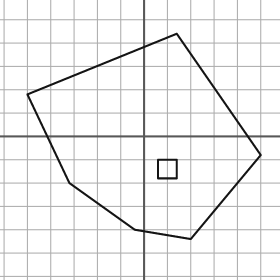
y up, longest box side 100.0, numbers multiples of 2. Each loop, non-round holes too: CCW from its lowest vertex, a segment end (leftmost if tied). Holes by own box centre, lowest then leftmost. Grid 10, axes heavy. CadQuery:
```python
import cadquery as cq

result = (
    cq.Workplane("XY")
    .moveTo(20.0, -44.0)
    .lineTo(50.0, -8.0)
    .lineTo(14.0, 44.0)
    .lineTo(-50.0, 18.0)
    .lineTo(-32.0, -20.0)
    .lineTo(-4.0, -40.0)
    .close()
    .moveTo(6.0, -18.0)
    .lineTo(14.0, -18.0)
    .lineTo(14.0, -10.0)
    .lineTo(6.0, -10.0)
    .close()
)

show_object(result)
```